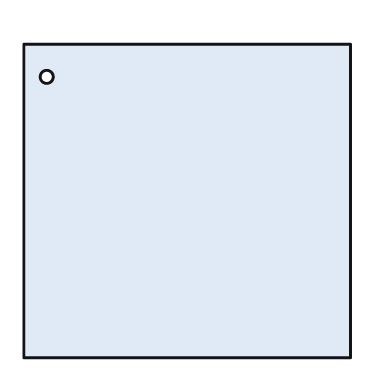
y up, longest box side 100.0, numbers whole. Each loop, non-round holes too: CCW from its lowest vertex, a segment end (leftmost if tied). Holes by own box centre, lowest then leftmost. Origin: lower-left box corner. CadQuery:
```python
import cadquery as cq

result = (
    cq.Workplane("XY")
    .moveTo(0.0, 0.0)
    .lineTo(100.0, 0.0)
    .lineTo(100.0, 96.0)
    .lineTo(0.0, 96.0)
    .close()
    .moveTo(7.0, 86.0)
    .circle(2.0)
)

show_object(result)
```